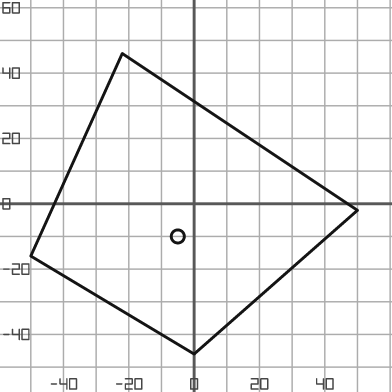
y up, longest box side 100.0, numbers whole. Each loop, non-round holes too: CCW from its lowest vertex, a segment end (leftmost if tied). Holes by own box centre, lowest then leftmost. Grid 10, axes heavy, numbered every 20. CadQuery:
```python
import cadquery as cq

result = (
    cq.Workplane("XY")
    .moveTo(0.0, -46.0)
    .lineTo(50.0, -2.0)
    .lineTo(-22.0, 46.0)
    .lineTo(-50.0, -16.0)
    .close()
    .moveTo(-5.0, -10.0)
    .circle(2.0)
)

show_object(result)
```